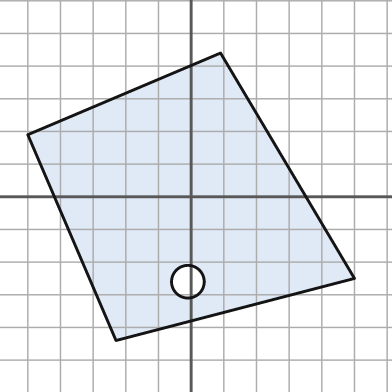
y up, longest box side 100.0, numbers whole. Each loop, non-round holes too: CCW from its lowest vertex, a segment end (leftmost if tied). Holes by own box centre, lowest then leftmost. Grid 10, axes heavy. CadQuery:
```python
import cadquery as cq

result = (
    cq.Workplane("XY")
    .moveTo(-23.0, -44.0)
    .lineTo(50.0, -25.0)
    .lineTo(9.0, 44.0)
    .lineTo(-50.0, 19.0)
    .close()
    .moveTo(-1.0, -26.0)
    .circle(5.0)
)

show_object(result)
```